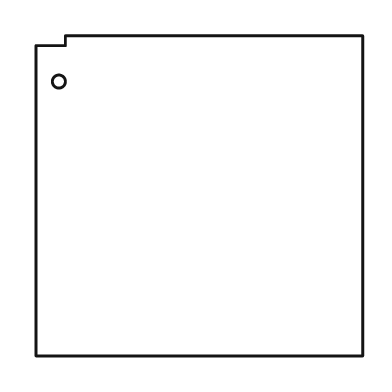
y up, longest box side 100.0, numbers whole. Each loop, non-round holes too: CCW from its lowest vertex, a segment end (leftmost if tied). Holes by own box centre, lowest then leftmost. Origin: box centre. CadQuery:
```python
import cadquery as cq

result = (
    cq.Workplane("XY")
    .moveTo(-50.0, -49.0)
    .lineTo(50.0, -49.0)
    .lineTo(50.0, 49.0)
    .lineTo(-41.0, 49.0)
    .lineTo(-41.0, 46.0)
    .lineTo(-50.0, 46.0)
    .close()
    .moveTo(-43.0, 35.0)
    .circle(2.0)
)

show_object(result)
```